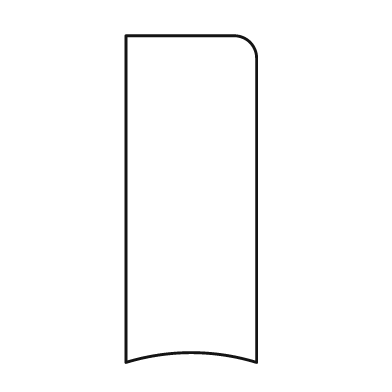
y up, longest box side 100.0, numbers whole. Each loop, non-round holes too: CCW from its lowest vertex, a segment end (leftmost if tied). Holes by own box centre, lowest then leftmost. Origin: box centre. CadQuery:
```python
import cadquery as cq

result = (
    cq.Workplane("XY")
    .moveTo(-20.0, -50.0)
    .threePointArc((0.0, -47.0), (20.0, -50.0))
    .lineTo(20.0, 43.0)
    .threePointArc((18.0, 48.0), (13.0, 50.0))
    .lineTo(-20.0, 50.0)
    .close()
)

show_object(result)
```